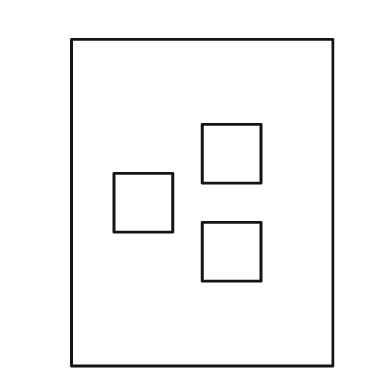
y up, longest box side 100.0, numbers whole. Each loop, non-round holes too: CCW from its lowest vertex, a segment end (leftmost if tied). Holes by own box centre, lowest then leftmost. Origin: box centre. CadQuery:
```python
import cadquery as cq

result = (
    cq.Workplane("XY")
    .moveTo(-40.0, -50.0)
    .lineTo(40.0, -50.0)
    .lineTo(40.0, 50.0)
    .lineTo(-40.0, 50.0)
    .close()
    .moveTo(0.0, -24.0)
    .lineTo(18.0, -24.0)
    .lineTo(18.0, -6.0)
    .lineTo(0.0, -6.0)
    .close()
    .moveTo(-27.0, -9.0)
    .lineTo(-9.0, -9.0)
    .lineTo(-9.0, 9.0)
    .lineTo(-27.0, 9.0)
    .close()
    .moveTo(0.0, 6.0)
    .lineTo(18.0, 6.0)
    .lineTo(18.0, 24.0)
    .lineTo(0.0, 24.0)
    .close()
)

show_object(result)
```